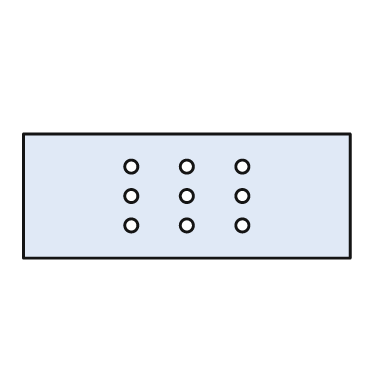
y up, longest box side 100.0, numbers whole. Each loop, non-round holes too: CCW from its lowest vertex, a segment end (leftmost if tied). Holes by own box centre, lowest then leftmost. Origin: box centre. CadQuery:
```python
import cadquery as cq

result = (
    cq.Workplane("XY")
    .moveTo(-50.0, -19.0)
    .lineTo(50.0, -19.0)
    .lineTo(50.0, 19.0)
    .lineTo(-50.0, 19.0)
    .close()
    .moveTo(-17.0, -9.0)
    .circle(2.0)
    .moveTo(0.0, -9.0)
    .circle(2.0)
    .moveTo(17.0, -9.0)
    .circle(2.0)
    .moveTo(-17.0, 0.0)
    .circle(2.0)
    .moveTo(0.0, 0.0)
    .circle(2.0)
    .moveTo(17.0, 0.0)
    .circle(2.0)
    .moveTo(-17.0, 9.0)
    .circle(2.0)
    .moveTo(0.0, 9.0)
    .circle(2.0)
    .moveTo(17.0, 9.0)
    .circle(2.0)
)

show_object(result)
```